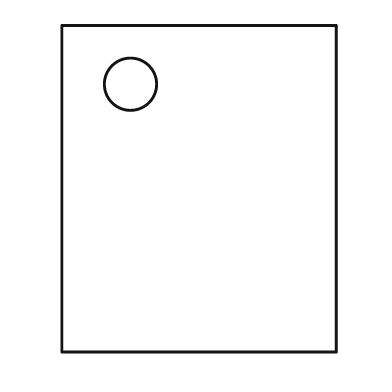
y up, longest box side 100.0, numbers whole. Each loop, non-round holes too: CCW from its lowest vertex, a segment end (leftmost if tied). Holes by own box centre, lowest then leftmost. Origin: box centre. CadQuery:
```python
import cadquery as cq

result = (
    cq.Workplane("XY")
    .moveTo(-42.0, -50.0)
    .lineTo(42.0, -50.0)
    .lineTo(42.0, 50.0)
    .lineTo(-42.0, 50.0)
    .close()
    .moveTo(-21.0, 32.0)
    .circle(8.0)
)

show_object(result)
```